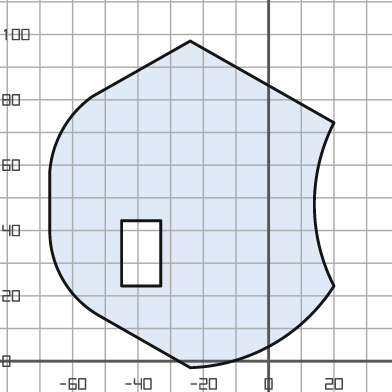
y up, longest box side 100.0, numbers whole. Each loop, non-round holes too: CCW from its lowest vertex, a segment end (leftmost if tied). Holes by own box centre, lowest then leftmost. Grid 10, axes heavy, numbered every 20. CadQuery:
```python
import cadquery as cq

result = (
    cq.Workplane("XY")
    .moveTo(-24.0, -2.0)
    .threePointArc((1.0, 5.0), (20.0, 23.0))
    .threePointArc((14.0, 48.0), (20.0, 73.0))
    .lineTo(-24.0, 98.0)
    .lineTo(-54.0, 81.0)
    .threePointArc((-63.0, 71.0), (-67.0, 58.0))
    .lineTo(-67.0, 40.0)
    .threePointArc((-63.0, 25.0), (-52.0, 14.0))
    .close()
    .moveTo(-45.0, 23.0)
    .lineTo(-33.0, 23.0)
    .lineTo(-33.0, 43.0)
    .lineTo(-45.0, 43.0)
    .close()
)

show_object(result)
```